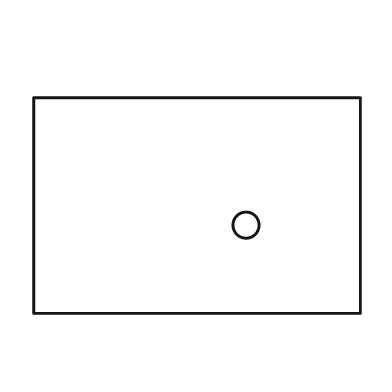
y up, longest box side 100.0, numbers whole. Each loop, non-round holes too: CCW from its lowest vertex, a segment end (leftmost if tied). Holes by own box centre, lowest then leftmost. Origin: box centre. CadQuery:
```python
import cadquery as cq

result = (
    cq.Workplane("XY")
    .moveTo(-50.0, -33.0)
    .lineTo(50.0, -33.0)
    .lineTo(50.0, 33.0)
    .lineTo(-50.0, 33.0)
    .close()
    .moveTo(15.0, -6.0)
    .circle(4.0)
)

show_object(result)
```